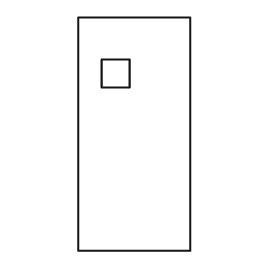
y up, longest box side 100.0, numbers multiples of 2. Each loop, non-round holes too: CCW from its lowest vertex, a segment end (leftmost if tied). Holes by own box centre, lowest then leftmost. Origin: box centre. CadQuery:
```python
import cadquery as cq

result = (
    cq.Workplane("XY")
    .moveTo(-24.0, -50.0)
    .lineTo(24.0, -50.0)
    .lineTo(24.0, 50.0)
    .lineTo(-24.0, 50.0)
    .close()
    .moveTo(-14.0, 20.0)
    .lineTo(-2.0, 20.0)
    .lineTo(-2.0, 32.0)
    .lineTo(-14.0, 32.0)
    .close()
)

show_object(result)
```